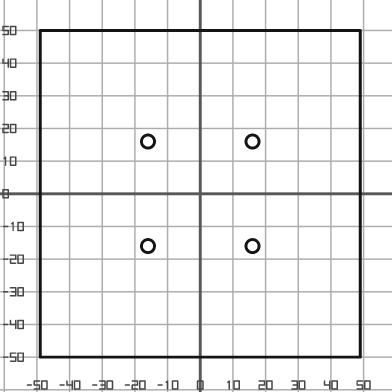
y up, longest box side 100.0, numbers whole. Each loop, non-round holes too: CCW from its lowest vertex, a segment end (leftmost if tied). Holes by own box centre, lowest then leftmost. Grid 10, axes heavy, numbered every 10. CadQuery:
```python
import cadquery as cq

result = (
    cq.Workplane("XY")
    .moveTo(-49.0, -50.0)
    .lineTo(49.0, -50.0)
    .lineTo(49.0, 50.0)
    .lineTo(-49.0, 50.0)
    .close()
    .moveTo(-16.0, -16.0)
    .circle(2.0)
    .moveTo(16.0, -16.0)
    .circle(2.0)
    .moveTo(-16.0, 16.0)
    .circle(2.0)
    .moveTo(16.0, 16.0)
    .circle(2.0)
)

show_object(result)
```